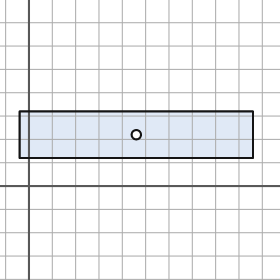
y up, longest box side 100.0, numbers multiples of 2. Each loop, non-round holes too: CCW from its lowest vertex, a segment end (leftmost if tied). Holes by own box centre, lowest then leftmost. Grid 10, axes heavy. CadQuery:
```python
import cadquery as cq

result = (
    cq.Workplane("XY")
    .moveTo(-4.0, 12.0)
    .lineTo(96.0, 12.0)
    .lineTo(96.0, 32.0)
    .lineTo(-4.0, 32.0)
    .close()
    .moveTo(46.0, 22.0)
    .circle(2.0)
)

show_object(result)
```